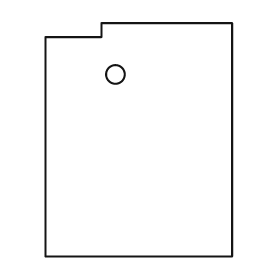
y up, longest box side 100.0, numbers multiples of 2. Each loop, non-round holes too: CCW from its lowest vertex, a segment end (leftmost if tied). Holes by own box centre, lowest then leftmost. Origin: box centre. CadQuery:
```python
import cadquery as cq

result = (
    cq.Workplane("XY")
    .moveTo(-40.0, -50.0)
    .lineTo(40.0, -50.0)
    .lineTo(40.0, 50.0)
    .lineTo(-16.0, 50.0)
    .lineTo(-16.0, 44.0)
    .lineTo(-40.0, 44.0)
    .close()
    .moveTo(-10.0, 28.0)
    .circle(4.0)
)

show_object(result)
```